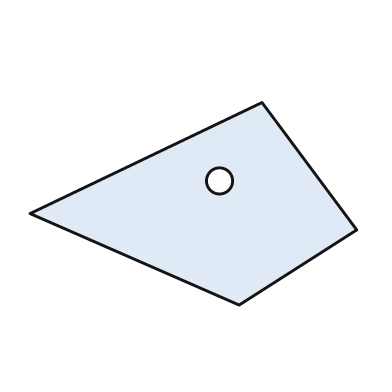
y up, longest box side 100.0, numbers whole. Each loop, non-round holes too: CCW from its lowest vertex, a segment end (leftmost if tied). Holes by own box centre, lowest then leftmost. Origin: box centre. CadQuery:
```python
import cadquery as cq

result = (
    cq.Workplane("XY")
    .moveTo(14.0, -31.0)
    .lineTo(50.0, -8.0)
    .lineTo(21.0, 31.0)
    .lineTo(-50.0, -3.0)
    .close()
    .moveTo(8.0, 7.0)
    .circle(4.0)
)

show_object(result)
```